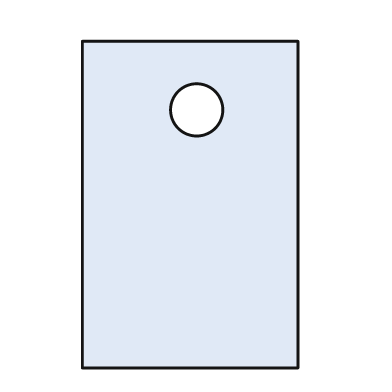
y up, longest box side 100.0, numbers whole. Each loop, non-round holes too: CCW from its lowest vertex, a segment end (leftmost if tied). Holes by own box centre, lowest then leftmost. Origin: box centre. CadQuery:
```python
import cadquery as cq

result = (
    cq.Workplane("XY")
    .moveTo(-33.0, -50.0)
    .lineTo(33.0, -50.0)
    .lineTo(33.0, 50.0)
    .lineTo(-33.0, 50.0)
    .close()
    .moveTo(2.0, 29.0)
    .circle(8.0)
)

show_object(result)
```